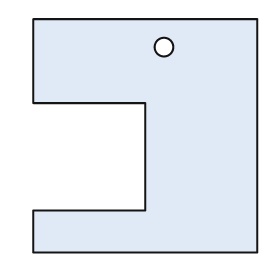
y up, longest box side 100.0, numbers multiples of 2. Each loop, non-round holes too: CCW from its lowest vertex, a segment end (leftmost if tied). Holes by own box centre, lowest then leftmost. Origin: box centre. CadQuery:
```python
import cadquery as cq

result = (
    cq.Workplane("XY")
    .moveTo(-48.0, -50.0)
    .lineTo(48.0, -50.0)
    .lineTo(48.0, 50.0)
    .lineTo(-48.0, 50.0)
    .lineTo(-48.0, 14.0)
    .lineTo(0.0, 14.0)
    .lineTo(0.0, -32.0)
    .lineTo(-48.0, -32.0)
    .close()
    .moveTo(8.0, 38.0)
    .circle(4.0)
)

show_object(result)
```